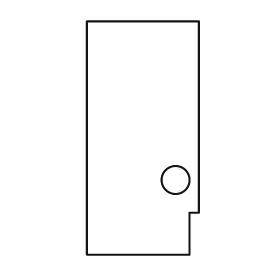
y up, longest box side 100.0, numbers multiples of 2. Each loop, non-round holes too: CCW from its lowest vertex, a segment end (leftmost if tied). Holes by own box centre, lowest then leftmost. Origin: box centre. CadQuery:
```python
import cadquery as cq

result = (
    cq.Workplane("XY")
    .moveTo(-24.0, -50.0)
    .lineTo(20.0, -50.0)
    .lineTo(20.0, -32.0)
    .lineTo(24.0, -32.0)
    .lineTo(24.0, 50.0)
    .lineTo(-24.0, 50.0)
    .close()
    .moveTo(14.0, -18.0)
    .circle(6.0)
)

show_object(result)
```